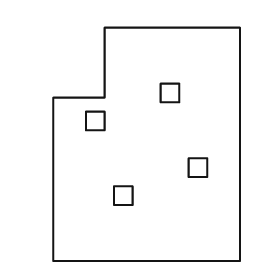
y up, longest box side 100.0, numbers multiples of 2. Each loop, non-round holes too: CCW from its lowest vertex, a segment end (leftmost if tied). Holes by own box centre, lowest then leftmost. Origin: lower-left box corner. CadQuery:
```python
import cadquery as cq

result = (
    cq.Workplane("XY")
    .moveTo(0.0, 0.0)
    .lineTo(80.0, 0.0)
    .lineTo(80.0, 100.0)
    .lineTo(22.0, 100.0)
    .lineTo(22.0, 70.0)
    .lineTo(0.0, 70.0)
    .close()
    .moveTo(26.0, 24.0)
    .lineTo(34.0, 24.0)
    .lineTo(34.0, 32.0)
    .lineTo(26.0, 32.0)
    .close()
    .moveTo(58.0, 36.0)
    .lineTo(66.0, 36.0)
    .lineTo(66.0, 44.0)
    .lineTo(58.0, 44.0)
    .close()
    .moveTo(14.0, 56.0)
    .lineTo(22.0, 56.0)
    .lineTo(22.0, 64.0)
    .lineTo(14.0, 64.0)
    .close()
    .moveTo(46.0, 68.0)
    .lineTo(54.0, 68.0)
    .lineTo(54.0, 76.0)
    .lineTo(46.0, 76.0)
    .close()
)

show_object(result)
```